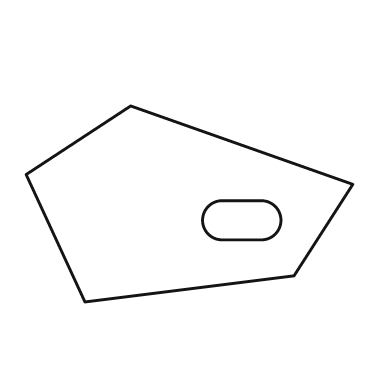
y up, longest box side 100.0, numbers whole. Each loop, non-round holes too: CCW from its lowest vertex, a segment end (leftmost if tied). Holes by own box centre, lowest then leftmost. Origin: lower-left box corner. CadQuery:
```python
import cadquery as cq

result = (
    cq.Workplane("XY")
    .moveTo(18.0, 0.0)
    .lineTo(82.0, 8.0)
    .lineTo(100.0, 36.0)
    .lineTo(32.0, 60.0)
    .lineTo(0.0, 39.0)
    .close()
    .moveTo(60.0, 19.0)
    .lineTo(72.0, 19.0)
    .threePointArc((78.0, 25.0), (72.0, 31.0))
    .lineTo(60.0, 31.0)
    .threePointArc((54.0, 25.0), (60.0, 19.0))
    .close()
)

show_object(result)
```